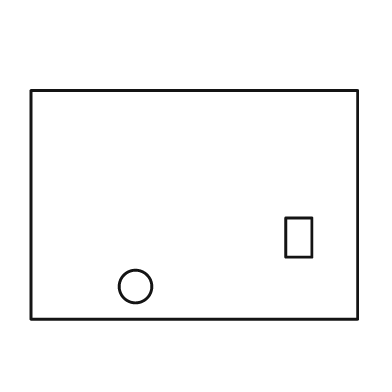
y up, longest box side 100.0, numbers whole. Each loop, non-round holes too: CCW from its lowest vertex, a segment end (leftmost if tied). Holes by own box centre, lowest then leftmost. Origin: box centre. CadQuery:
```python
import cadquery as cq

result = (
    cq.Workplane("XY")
    .moveTo(-50.0, -35.0)
    .lineTo(50.0, -35.0)
    .lineTo(50.0, 35.0)
    .lineTo(-50.0, 35.0)
    .close()
    .moveTo(-18.0, -25.0)
    .circle(5.0)
    .moveTo(28.0, -16.0)
    .lineTo(36.0, -16.0)
    .lineTo(36.0, -4.0)
    .lineTo(28.0, -4.0)
    .close()
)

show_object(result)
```